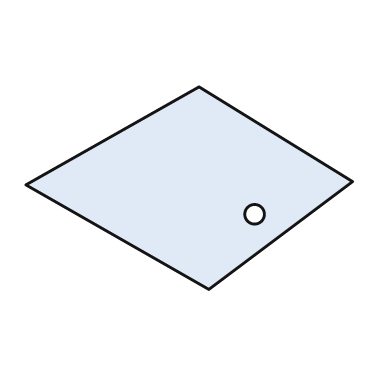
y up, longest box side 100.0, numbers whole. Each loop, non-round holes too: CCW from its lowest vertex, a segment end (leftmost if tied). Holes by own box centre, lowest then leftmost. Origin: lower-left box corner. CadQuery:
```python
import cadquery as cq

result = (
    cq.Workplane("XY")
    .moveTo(56.0, 0.0)
    .lineTo(100.0, 33.0)
    .lineTo(53.0, 62.0)
    .lineTo(0.0, 32.0)
    .close()
    .moveTo(70.0, 23.0)
    .circle(3.0)
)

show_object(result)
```